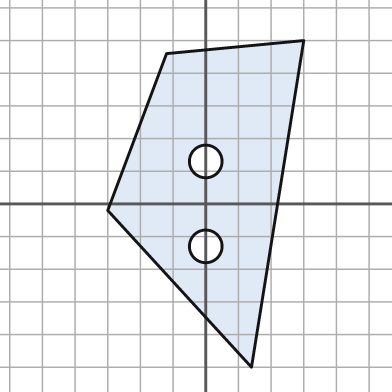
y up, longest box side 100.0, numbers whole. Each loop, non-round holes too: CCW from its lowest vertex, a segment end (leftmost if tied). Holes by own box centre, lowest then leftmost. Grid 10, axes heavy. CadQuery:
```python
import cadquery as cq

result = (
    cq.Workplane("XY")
    .moveTo(14.0, -50.0)
    .lineTo(30.0, 50.0)
    .lineTo(-12.0, 46.0)
    .lineTo(-30.0, -2.0)
    .close()
    .moveTo(0.0, -13.0)
    .circle(5.0)
    .moveTo(0.0, 13.0)
    .circle(5.0)
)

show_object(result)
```